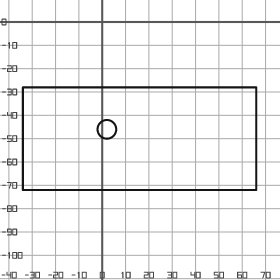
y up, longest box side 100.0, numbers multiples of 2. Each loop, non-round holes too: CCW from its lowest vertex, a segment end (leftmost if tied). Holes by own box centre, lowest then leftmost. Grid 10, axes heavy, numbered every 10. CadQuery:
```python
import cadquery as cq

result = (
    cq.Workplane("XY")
    .moveTo(-34.0, -72.0)
    .lineTo(66.0, -72.0)
    .lineTo(66.0, -28.0)
    .lineTo(-34.0, -28.0)
    .close()
    .moveTo(2.0, -46.0)
    .circle(4.0)
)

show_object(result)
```